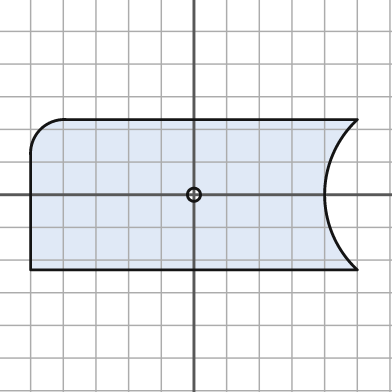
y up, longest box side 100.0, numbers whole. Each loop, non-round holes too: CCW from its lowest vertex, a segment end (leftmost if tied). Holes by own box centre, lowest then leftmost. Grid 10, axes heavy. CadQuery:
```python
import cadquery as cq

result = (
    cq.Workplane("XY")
    .moveTo(-50.0, -23.0)
    .lineTo(50.0, -23.0)
    .threePointArc((40.0, 0.0), (50.0, 23.0))
    .lineTo(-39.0, 23.0)
    .threePointArc((-47.0, 20.0), (-50.0, 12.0))
    .close()
    .moveTo(0.0, 0.0)
    .circle(2.0)
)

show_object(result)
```